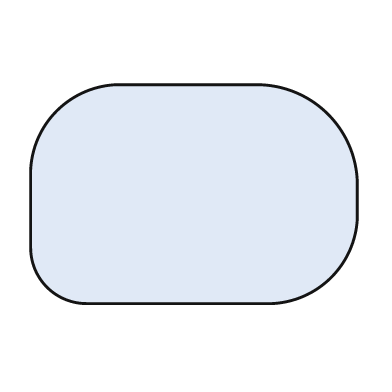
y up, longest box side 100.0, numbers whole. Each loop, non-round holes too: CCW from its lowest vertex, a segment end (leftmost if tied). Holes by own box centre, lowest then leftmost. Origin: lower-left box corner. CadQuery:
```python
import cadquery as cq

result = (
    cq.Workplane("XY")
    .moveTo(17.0, 0.0)
    .lineTo(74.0, 0.0)
    .threePointArc((92.0, 8.0), (100.0, 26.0))
    .lineTo(100.0, 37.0)
    .threePointArc((91.0, 58.0), (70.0, 67.0))
    .lineTo(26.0, 67.0)
    .threePointArc((8.0, 59.0), (0.0, 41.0))
    .lineTo(0.0, 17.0)
    .threePointArc((5.0, 5.0), (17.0, 0.0))
    .close()
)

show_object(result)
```